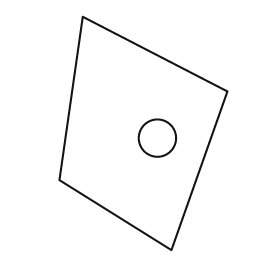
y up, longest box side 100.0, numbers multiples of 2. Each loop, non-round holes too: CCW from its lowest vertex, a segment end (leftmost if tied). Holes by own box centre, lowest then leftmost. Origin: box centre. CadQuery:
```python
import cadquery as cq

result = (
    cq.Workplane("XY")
    .moveTo(12.0, -50.0)
    .lineTo(36.0, 18.0)
    .lineTo(-26.0, 50.0)
    .lineTo(-36.0, -20.0)
    .close()
    .moveTo(6.0, -2.0)
    .circle(8.0)
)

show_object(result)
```